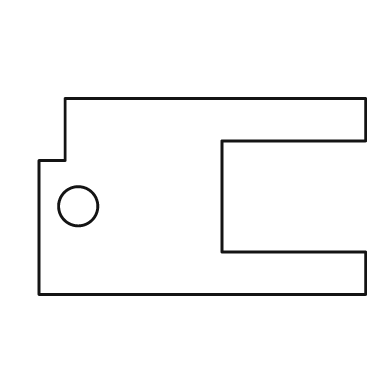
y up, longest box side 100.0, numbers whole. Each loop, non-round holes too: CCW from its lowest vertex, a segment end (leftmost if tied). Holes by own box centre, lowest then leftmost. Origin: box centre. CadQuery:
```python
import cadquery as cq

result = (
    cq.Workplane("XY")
    .moveTo(-50.0, -30.0)
    .lineTo(50.0, -30.0)
    .lineTo(50.0, -17.0)
    .lineTo(6.0, -17.0)
    .lineTo(6.0, 17.0)
    .lineTo(50.0, 17.0)
    .lineTo(50.0, 30.0)
    .lineTo(-42.0, 30.0)
    .lineTo(-42.0, 11.0)
    .lineTo(-50.0, 11.0)
    .close()
    .moveTo(-38.0, -3.0)
    .circle(6.0)
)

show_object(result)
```